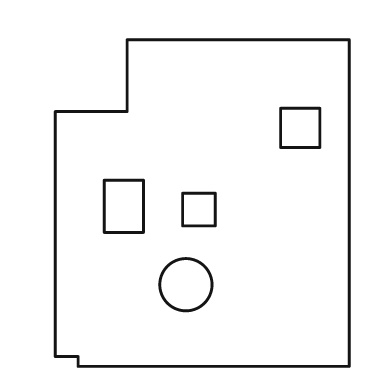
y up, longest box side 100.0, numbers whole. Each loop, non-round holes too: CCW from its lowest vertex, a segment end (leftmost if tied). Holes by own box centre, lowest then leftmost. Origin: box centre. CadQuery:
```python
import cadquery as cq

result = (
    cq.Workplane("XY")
    .moveTo(-38.0, -50.0)
    .lineTo(45.0, -50.0)
    .lineTo(45.0, 50.0)
    .lineTo(-23.0, 50.0)
    .lineTo(-23.0, 28.0)
    .lineTo(-45.0, 28.0)
    .lineTo(-45.0, -47.0)
    .lineTo(-38.0, -47.0)
    .close()
    .moveTo(-5.0, -25.0)
    .circle(8.0)
    .moveTo(-6.0, -7.0)
    .lineTo(4.0, -7.0)
    .lineTo(4.0, 3.0)
    .lineTo(-6.0, 3.0)
    .close()
    .moveTo(-30.0, -9.0)
    .lineTo(-18.0, -9.0)
    .lineTo(-18.0, 7.0)
    .lineTo(-30.0, 7.0)
    .close()
    .moveTo(24.0, 17.0)
    .lineTo(36.0, 17.0)
    .lineTo(36.0, 29.0)
    .lineTo(24.0, 29.0)
    .close()
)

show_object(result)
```